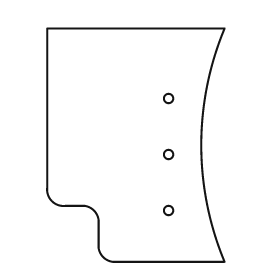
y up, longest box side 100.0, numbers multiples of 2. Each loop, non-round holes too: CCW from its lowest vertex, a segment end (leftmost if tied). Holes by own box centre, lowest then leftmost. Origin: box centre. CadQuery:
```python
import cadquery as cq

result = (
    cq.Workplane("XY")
    .moveTo(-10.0, -50.0)
    .lineTo(38.0, -50.0)
    .threePointArc((28.0, 0.0), (38.0, 50.0))
    .lineTo(-38.0, 50.0)
    .lineTo(-38.0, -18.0)
    .threePointArc((-36.0, -24.0), (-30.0, -26.0))
    .lineTo(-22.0, -26.0)
    .threePointArc((-18.0, -28.0), (-16.0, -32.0))
    .lineTo(-16.0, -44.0)
    .threePointArc((-14.0, -48.0), (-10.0, -50.0))
    .close()
    .moveTo(14.0, -28.0)
    .circle(2.0)
    .moveTo(14.0, -4.0)
    .circle(2.0)
    .moveTo(14.0, 20.0)
    .circle(2.0)
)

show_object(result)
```